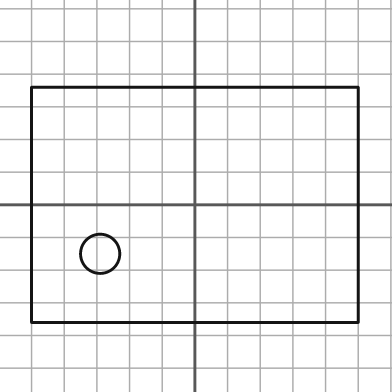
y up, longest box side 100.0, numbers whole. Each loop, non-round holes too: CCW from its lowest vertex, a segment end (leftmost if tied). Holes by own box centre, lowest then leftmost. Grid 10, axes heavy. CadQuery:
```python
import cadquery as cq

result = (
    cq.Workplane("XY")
    .moveTo(-50.0, -36.0)
    .lineTo(50.0, -36.0)
    .lineTo(50.0, 36.0)
    .lineTo(-50.0, 36.0)
    .close()
    .moveTo(-29.0, -15.0)
    .circle(6.0)
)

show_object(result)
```